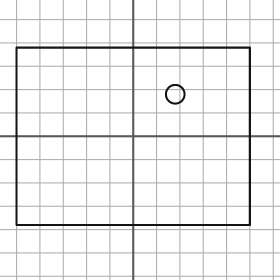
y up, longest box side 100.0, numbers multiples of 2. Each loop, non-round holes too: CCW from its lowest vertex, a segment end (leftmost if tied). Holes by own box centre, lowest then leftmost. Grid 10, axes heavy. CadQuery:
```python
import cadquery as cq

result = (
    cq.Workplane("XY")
    .moveTo(-50.0, -38.0)
    .lineTo(50.0, -38.0)
    .lineTo(50.0, 38.0)
    .lineTo(-50.0, 38.0)
    .close()
    .moveTo(18.0, 18.0)
    .circle(4.0)
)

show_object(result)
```